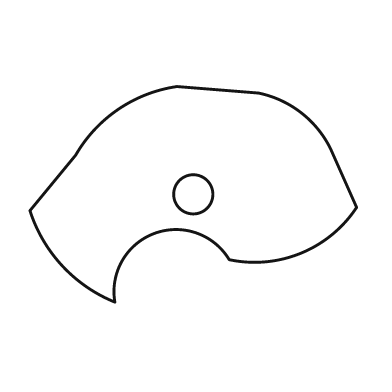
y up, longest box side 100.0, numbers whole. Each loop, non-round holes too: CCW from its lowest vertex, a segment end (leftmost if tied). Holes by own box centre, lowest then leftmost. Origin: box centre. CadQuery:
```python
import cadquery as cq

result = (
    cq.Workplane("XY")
    .moveTo(-24.0, -33.0)
    .threePointArc((-12.0, -12.0), (11.0, -20.0))
    .threePointArc((33.0, -18.0), (50.0, -4.0))
    .lineTo(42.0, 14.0)
    .threePointArc((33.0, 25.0), (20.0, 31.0))
    .lineTo(-5.0, 33.0)
    .threePointArc((-23.0, 26.0), (-36.0, 12.0))
    .lineTo(-50.0, -5.0)
    .threePointArc((-40.0, -22.0), (-24.0, -33.0))
    .close()
    .moveTo(0.0, 0.0)
    .circle(6.0)
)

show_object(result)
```